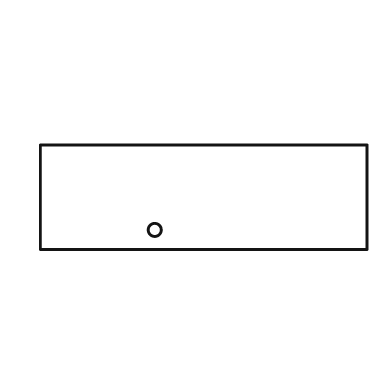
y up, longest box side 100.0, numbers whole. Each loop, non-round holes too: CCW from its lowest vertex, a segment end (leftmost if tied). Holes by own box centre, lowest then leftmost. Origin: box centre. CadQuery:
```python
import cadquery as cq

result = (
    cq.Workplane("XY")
    .moveTo(-50.0, -16.0)
    .lineTo(50.0, -16.0)
    .lineTo(50.0, 16.0)
    .lineTo(-50.0, 16.0)
    .close()
    .moveTo(-15.0, -10.0)
    .circle(2.0)
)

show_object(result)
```